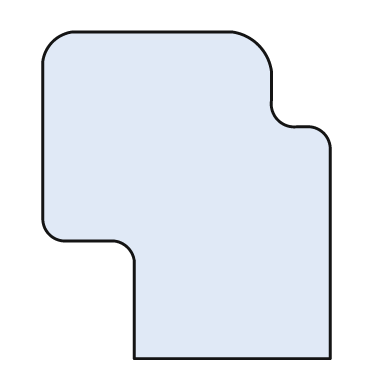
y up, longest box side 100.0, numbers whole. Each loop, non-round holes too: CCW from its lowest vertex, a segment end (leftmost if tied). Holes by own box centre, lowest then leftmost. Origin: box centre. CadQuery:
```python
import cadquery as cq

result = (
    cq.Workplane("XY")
    .moveTo(-16.0, -50.0)
    .lineTo(44.0, -50.0)
    .lineTo(44.0, 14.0)
    .threePointArc((42.0, 19.0), (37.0, 21.0))
    .lineTo(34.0, 21.0)
    .threePointArc((28.0, 23.0), (26.0, 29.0))
    .lineTo(26.0, 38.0)
    .threePointArc((22.0, 46.0), (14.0, 50.0))
    .lineTo(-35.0, 50.0)
    .threePointArc((-41.0, 47.0), (-44.0, 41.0))
    .lineTo(-44.0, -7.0)
    .threePointArc((-42.0, -12.0), (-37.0, -14.0))
    .lineTo(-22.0, -14.0)
    .threePointArc((-18.0, -16.0), (-16.0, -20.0))
    .close()
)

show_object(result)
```